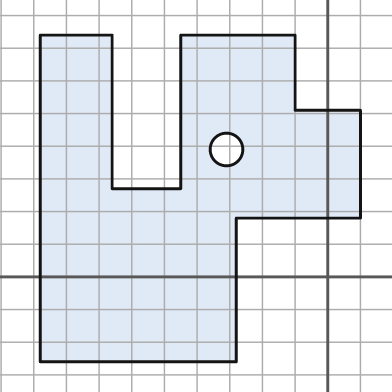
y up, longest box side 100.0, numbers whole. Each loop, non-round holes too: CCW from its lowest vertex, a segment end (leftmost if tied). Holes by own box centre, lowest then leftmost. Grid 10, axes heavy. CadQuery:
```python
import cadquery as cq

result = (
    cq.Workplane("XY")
    .moveTo(-88.0, -26.0)
    .lineTo(-28.0, -26.0)
    .lineTo(-28.0, 18.0)
    .lineTo(10.0, 18.0)
    .lineTo(10.0, 51.0)
    .lineTo(-10.0, 51.0)
    .lineTo(-10.0, 74.0)
    .lineTo(-45.0, 74.0)
    .lineTo(-45.0, 27.0)
    .lineTo(-66.0, 27.0)
    .lineTo(-66.0, 74.0)
    .lineTo(-88.0, 74.0)
    .close()
    .moveTo(-31.0, 39.0)
    .circle(5.0)
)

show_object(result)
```